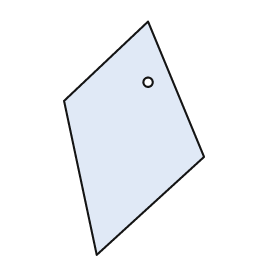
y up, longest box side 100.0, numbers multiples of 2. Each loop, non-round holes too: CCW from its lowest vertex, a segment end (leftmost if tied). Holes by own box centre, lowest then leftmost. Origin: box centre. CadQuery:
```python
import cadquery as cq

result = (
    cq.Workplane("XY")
    .moveTo(-16.0, -50.0)
    .lineTo(30.0, -8.0)
    .lineTo(6.0, 50.0)
    .lineTo(-30.0, 16.0)
    .close()
    .moveTo(6.0, 24.0)
    .circle(2.0)
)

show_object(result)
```